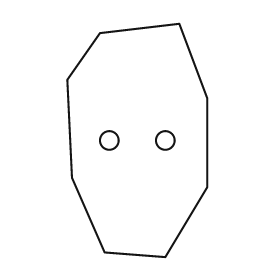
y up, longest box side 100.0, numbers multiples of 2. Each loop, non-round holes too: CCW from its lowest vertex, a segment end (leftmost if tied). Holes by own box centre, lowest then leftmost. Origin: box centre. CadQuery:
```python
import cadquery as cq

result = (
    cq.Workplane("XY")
    .moveTo(12.0, -50.0)
    .lineTo(30.0, -20.0)
    .lineTo(30.0, 18.0)
    .lineTo(18.0, 50.0)
    .lineTo(-16.0, 46.0)
    .lineTo(-30.0, 26.0)
    .lineTo(-28.0, -16.0)
    .lineTo(-14.0, -48.0)
    .close()
    .moveTo(-12.0, 0.0)
    .circle(4.0)
    .moveTo(12.0, 0.0)
    .circle(4.0)
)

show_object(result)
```